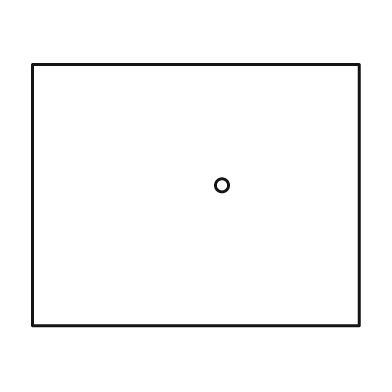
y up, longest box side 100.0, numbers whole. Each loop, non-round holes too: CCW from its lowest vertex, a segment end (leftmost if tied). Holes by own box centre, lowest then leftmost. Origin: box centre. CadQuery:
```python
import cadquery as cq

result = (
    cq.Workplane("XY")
    .moveTo(-50.0, -40.0)
    .lineTo(50.0, -40.0)
    .lineTo(50.0, 40.0)
    .lineTo(-50.0, 40.0)
    .close()
    .moveTo(8.0, 3.0)
    .circle(2.0)
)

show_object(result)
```